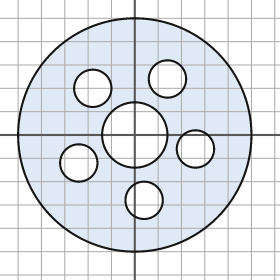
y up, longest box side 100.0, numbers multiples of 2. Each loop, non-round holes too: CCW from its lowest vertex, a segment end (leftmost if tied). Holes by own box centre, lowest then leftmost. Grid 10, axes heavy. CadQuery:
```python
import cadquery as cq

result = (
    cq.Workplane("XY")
    .moveTo(0.0, 0.0)
    .circle(50.0)
    .moveTo(4.0, -28.0)
    .circle(8.0)
    .moveTo(-24.0, -12.0)
    .circle(8.0)
    .moveTo(26.0, -6.0)
    .circle(8.0)
    .moveTo(0.0, 0.0)
    .circle(14.0)
    .moveTo(-18.0, 20.0)
    .circle(8.0)
    .moveTo(14.0, 24.0)
    .circle(8.0)
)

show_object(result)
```